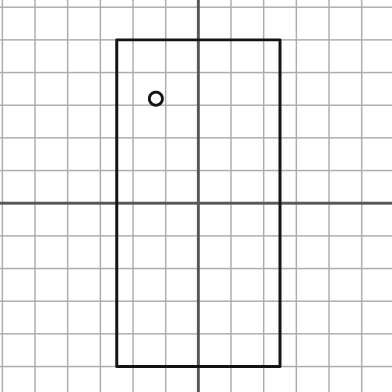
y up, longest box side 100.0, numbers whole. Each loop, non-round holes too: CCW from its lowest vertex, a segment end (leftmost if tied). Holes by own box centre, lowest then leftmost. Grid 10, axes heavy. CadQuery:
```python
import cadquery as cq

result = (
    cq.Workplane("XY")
    .moveTo(-25.0, -50.0)
    .lineTo(25.0, -50.0)
    .lineTo(25.0, 50.0)
    .lineTo(-25.0, 50.0)
    .close()
    .moveTo(-13.0, 32.0)
    .circle(2.0)
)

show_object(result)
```